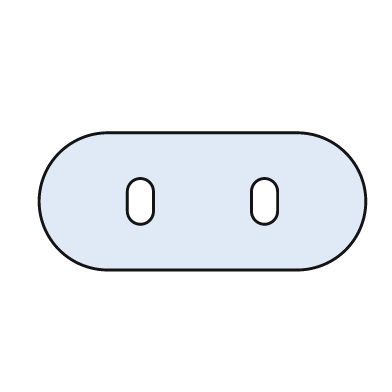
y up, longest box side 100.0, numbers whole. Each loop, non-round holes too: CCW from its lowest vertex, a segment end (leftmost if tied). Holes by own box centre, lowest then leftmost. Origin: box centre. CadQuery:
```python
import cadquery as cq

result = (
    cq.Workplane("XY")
    .moveTo(-29.0, -21.0)
    .lineTo(29.0, -21.0)
    .threePointArc((50.0, 0.0), (29.0, 21.0))
    .lineTo(-29.0, 21.0)
    .threePointArc((-50.0, 0.0), (-29.0, -21.0))
    .close()
    .moveTo(-23.0, -3.0)
    .threePointArc((-19.0, -7.0), (-15.0, -3.0))
    .lineTo(-15.0, 3.0)
    .threePointArc((-19.0, 7.0), (-23.0, 3.0))
    .close()
    .moveTo(15.0, -3.0)
    .threePointArc((19.0, -7.0), (23.0, -3.0))
    .lineTo(23.0, 3.0)
    .threePointArc((19.0, 7.0), (15.0, 3.0))
    .close()
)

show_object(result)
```